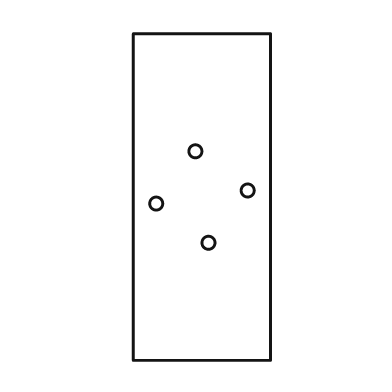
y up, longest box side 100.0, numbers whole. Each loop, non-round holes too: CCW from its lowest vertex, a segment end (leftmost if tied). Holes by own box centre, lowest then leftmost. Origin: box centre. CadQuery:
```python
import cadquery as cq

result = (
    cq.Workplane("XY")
    .moveTo(-21.0, -50.0)
    .lineTo(21.0, -50.0)
    .lineTo(21.0, 50.0)
    .lineTo(-21.0, 50.0)
    .close()
    .moveTo(2.0, -14.0)
    .circle(2.0)
    .moveTo(-14.0, -2.0)
    .circle(2.0)
    .moveTo(14.0, 2.0)
    .circle(2.0)
    .moveTo(-2.0, 14.0)
    .circle(2.0)
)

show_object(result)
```